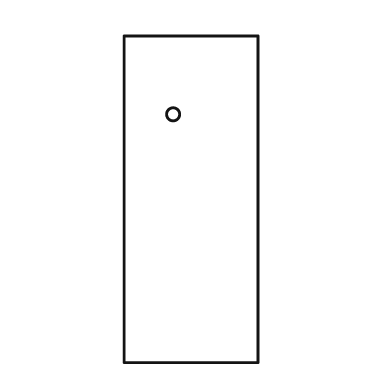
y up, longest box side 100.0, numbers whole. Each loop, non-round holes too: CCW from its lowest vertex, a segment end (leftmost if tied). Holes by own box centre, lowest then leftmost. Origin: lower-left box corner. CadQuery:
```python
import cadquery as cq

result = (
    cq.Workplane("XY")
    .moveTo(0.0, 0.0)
    .lineTo(41.0, 0.0)
    .lineTo(41.0, 100.0)
    .lineTo(0.0, 100.0)
    .close()
    .moveTo(15.0, 76.0)
    .circle(2.0)
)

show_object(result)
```